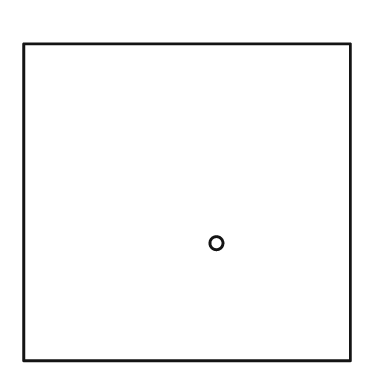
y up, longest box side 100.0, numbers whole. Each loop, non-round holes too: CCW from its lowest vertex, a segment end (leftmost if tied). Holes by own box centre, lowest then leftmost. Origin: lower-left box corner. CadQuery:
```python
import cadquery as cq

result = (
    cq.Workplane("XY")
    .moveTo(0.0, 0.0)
    .lineTo(100.0, 0.0)
    .lineTo(100.0, 97.0)
    .lineTo(0.0, 97.0)
    .close()
    .moveTo(59.0, 36.0)
    .circle(2.0)
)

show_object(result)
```